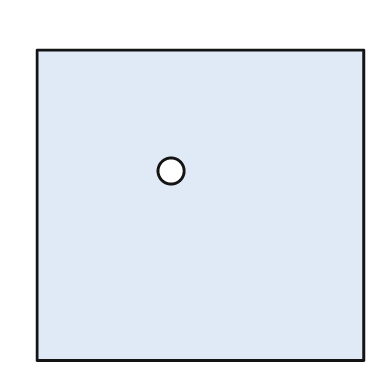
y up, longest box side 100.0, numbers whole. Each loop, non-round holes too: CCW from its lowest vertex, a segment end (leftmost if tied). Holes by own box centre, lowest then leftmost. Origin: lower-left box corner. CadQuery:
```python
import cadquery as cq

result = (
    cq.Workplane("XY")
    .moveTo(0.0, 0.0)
    .lineTo(100.0, 0.0)
    .lineTo(100.0, 95.0)
    .lineTo(0.0, 95.0)
    .close()
    .moveTo(41.0, 58.0)
    .circle(4.0)
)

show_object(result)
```